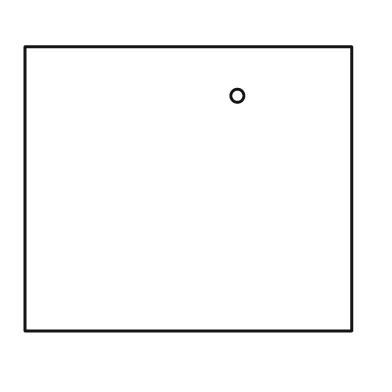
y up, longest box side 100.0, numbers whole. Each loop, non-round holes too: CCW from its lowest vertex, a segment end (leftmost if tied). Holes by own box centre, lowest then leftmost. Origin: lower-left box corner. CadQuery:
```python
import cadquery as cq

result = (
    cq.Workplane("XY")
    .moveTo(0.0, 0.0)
    .lineTo(100.0, 0.0)
    .lineTo(100.0, 87.0)
    .lineTo(0.0, 87.0)
    .close()
    .moveTo(65.0, 72.0)
    .circle(2.0)
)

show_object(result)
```